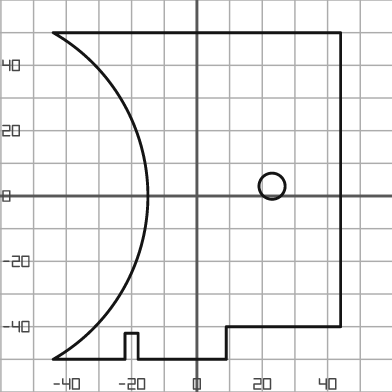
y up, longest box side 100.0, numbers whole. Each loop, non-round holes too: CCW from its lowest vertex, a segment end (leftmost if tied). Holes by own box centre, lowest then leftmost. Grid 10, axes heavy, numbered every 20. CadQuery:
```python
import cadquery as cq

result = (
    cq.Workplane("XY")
    .moveTo(-44.0, -50.0)
    .lineTo(-22.0, -50.0)
    .lineTo(-22.0, -42.0)
    .lineTo(-18.0, -42.0)
    .lineTo(-18.0, -50.0)
    .lineTo(9.0, -50.0)
    .lineTo(9.0, -40.0)
    .lineTo(44.0, -40.0)
    .lineTo(44.0, 50.0)
    .lineTo(-44.0, 50.0)
    .threePointArc((-15.0, 0.0), (-44.0, -50.0))
    .close()
    .moveTo(23.0, 3.0)
    .circle(4.0)
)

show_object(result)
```